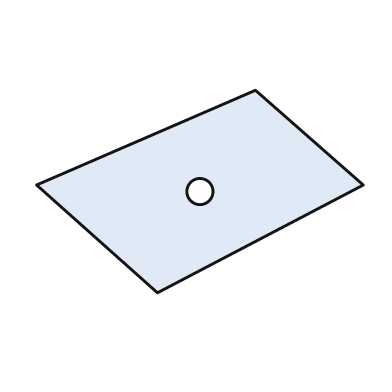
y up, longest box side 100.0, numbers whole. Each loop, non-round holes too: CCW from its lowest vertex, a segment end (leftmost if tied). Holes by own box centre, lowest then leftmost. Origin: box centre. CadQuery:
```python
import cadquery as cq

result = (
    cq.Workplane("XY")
    .moveTo(-13.0, -31.0)
    .lineTo(50.0, 2.0)
    .lineTo(17.0, 31.0)
    .lineTo(-50.0, 2.0)
    .close()
    .moveTo(0.0, 0.0)
    .circle(4.0)
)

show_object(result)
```